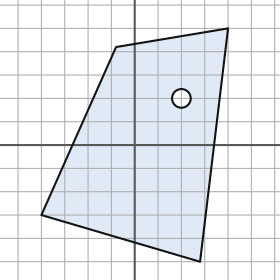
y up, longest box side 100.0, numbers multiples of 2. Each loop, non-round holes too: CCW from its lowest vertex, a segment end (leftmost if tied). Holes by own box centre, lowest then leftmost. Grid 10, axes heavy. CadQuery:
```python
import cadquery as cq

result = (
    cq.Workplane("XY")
    .moveTo(28.0, -50.0)
    .lineTo(40.0, 50.0)
    .lineTo(-8.0, 42.0)
    .lineTo(-40.0, -30.0)
    .close()
    .moveTo(20.0, 20.0)
    .circle(4.0)
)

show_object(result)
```